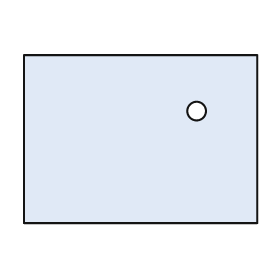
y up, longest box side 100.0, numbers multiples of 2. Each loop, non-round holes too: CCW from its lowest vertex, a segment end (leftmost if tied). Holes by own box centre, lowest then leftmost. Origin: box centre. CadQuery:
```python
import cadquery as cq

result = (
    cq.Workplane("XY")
    .moveTo(-50.0, -36.0)
    .lineTo(50.0, -36.0)
    .lineTo(50.0, 36.0)
    .lineTo(-50.0, 36.0)
    .close()
    .moveTo(24.0, 12.0)
    .circle(4.0)
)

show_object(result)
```